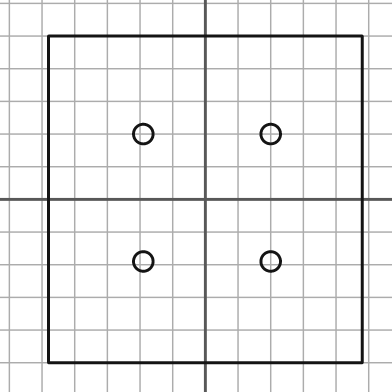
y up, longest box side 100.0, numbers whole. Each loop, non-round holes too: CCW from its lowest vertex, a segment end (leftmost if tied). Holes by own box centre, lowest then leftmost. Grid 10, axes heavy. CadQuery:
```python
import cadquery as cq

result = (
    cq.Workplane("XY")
    .moveTo(-48.0, -50.0)
    .lineTo(48.0, -50.0)
    .lineTo(48.0, 50.0)
    .lineTo(-48.0, 50.0)
    .close()
    .moveTo(-19.0, -19.0)
    .circle(3.0)
    .moveTo(20.0, -19.0)
    .circle(3.0)
    .moveTo(-19.0, 20.0)
    .circle(3.0)
    .moveTo(20.0, 20.0)
    .circle(3.0)
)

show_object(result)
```